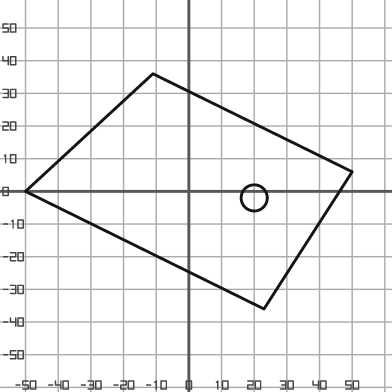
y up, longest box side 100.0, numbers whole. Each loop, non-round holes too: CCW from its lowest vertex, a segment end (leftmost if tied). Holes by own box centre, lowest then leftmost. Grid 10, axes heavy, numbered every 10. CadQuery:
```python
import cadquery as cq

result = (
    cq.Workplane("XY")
    .moveTo(23.0, -36.0)
    .lineTo(50.0, 6.0)
    .lineTo(-11.0, 36.0)
    .lineTo(-50.0, 0.0)
    .close()
    .moveTo(20.0, -2.0)
    .circle(4.0)
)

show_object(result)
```